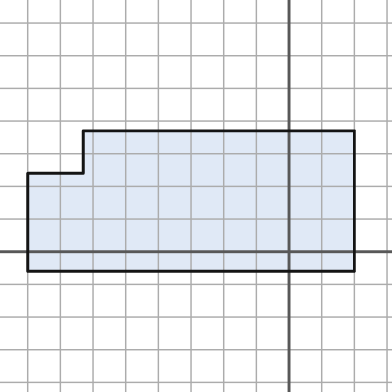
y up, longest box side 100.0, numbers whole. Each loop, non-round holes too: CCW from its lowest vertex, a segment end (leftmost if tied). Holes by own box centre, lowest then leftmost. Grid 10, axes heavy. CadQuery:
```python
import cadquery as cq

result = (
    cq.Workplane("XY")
    .moveTo(-80.0, -6.0)
    .lineTo(20.0, -6.0)
    .lineTo(20.0, 37.0)
    .lineTo(-63.0, 37.0)
    .lineTo(-63.0, 24.0)
    .lineTo(-80.0, 24.0)
    .close()
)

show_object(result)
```